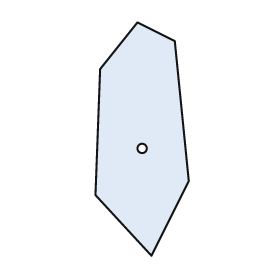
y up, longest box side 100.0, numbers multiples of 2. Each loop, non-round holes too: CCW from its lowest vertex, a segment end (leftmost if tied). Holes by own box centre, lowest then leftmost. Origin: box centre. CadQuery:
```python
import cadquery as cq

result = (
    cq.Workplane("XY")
    .moveTo(4.0, -50.0)
    .lineTo(20.0, -18.0)
    .lineTo(14.0, 42.0)
    .lineTo(-2.0, 50.0)
    .lineTo(-18.0, 30.0)
    .lineTo(-20.0, -24.0)
    .close()
    .moveTo(0.0, -4.0)
    .circle(2.0)
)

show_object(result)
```